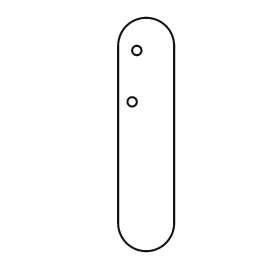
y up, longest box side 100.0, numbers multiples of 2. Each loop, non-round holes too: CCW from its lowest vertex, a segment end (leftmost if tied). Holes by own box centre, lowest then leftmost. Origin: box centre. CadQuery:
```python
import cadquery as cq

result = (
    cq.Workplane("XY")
    .moveTo(-12.0, -38.0)
    .threePointArc((0.0, -50.0), (12.0, -38.0))
    .lineTo(12.0, 38.0)
    .threePointArc((0.0, 50.0), (-12.0, 38.0))
    .close()
    .moveTo(-6.0, 14.0)
    .circle(2.0)
    .moveTo(-4.0, 36.0)
    .circle(2.0)
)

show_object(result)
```